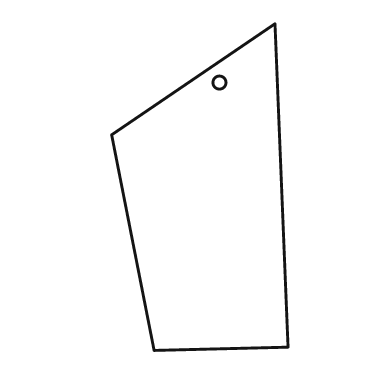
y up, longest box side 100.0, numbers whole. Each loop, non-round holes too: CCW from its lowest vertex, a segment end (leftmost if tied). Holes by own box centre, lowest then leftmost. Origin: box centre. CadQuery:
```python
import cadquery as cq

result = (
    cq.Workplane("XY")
    .moveTo(-14.0, -50.0)
    .lineTo(27.0, -49.0)
    .lineTo(23.0, 50.0)
    .lineTo(-27.0, 16.0)
    .close()
    .moveTo(6.0, 32.0)
    .circle(2.0)
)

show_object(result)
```